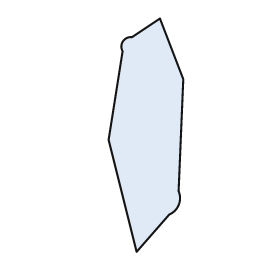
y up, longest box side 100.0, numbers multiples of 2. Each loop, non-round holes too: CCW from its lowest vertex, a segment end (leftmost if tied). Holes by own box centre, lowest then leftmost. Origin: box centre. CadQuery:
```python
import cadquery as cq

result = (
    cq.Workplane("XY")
    .moveTo(-4.0, -50.0)
    .lineTo(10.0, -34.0)
    .threePointArc((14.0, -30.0), (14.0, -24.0))
    .lineTo(16.0, 24.0)
    .lineTo(6.0, 50.0)
    .lineTo(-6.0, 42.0)
    .threePointArc((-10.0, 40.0), (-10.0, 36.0))
    .lineTo(-16.0, -2.0)
    .close()
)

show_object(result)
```